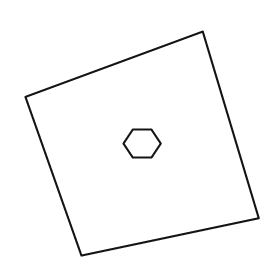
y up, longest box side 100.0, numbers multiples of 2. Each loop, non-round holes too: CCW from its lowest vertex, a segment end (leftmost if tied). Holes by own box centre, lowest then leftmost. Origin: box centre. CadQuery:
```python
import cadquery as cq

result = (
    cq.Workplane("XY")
    .moveTo(-26.0, -48.0)
    .lineTo(50.0, -32.0)
    .lineTo(26.0, 48.0)
    .lineTo(-50.0, 20.0)
    .close()
    .moveTo(-4.0, -6.0)
    .lineTo(4.0, -6.0)
    .lineTo(8.0, 0.0)
    .lineTo(4.0, 6.0)
    .lineTo(-4.0, 6.0)
    .lineTo(-8.0, 0.0)
    .close()
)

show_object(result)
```